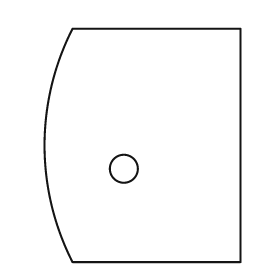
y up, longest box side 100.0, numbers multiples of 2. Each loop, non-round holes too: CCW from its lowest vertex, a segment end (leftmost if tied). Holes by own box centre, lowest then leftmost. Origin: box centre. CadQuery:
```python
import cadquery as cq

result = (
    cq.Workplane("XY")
    .moveTo(-30.0, -50.0)
    .lineTo(42.0, -50.0)
    .lineTo(42.0, 50.0)
    .lineTo(-30.0, 50.0)
    .threePointArc((-42.0, 0.0), (-30.0, -50.0))
    .close()
    .moveTo(-8.0, -10.0)
    .circle(6.0)
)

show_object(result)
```